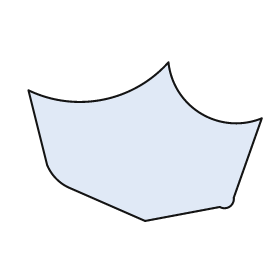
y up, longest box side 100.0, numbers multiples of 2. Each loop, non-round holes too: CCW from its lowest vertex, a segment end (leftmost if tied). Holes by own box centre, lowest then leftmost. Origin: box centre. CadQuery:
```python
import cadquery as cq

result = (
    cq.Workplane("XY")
    .moveTo(0.0, -34.0)
    .lineTo(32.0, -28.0)
    .threePointArc((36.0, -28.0), (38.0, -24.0))
    .lineTo(50.0, 10.0)
    .threePointArc((24.0, 12.0), (10.0, 34.0))
    .threePointArc((-18.0, 18.0), (-50.0, 22.0))
    .lineTo(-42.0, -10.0)
    .threePointArc((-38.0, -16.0), (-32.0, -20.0))
    .close()
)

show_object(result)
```